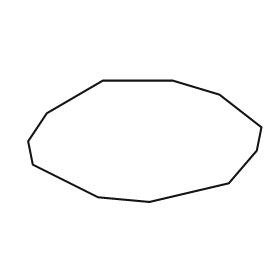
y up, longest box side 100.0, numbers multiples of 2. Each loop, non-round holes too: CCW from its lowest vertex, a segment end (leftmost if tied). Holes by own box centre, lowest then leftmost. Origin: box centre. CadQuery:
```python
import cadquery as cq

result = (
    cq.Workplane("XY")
    .moveTo(2.0, -26.0)
    .lineTo(36.0, -18.0)
    .lineTo(48.0, -4.0)
    .lineTo(50.0, 6.0)
    .lineTo(32.0, 20.0)
    .lineTo(12.0, 26.0)
    .lineTo(-18.0, 26.0)
    .lineTo(-42.0, 12.0)
    .lineTo(-50.0, 0.0)
    .lineTo(-48.0, -10.0)
    .lineTo(-20.0, -24.0)
    .close()
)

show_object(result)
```